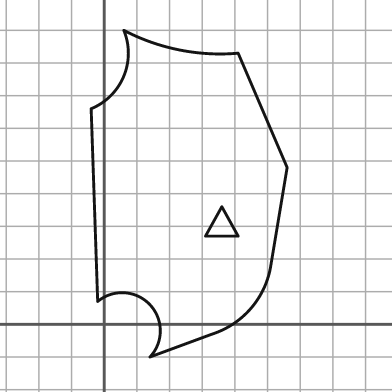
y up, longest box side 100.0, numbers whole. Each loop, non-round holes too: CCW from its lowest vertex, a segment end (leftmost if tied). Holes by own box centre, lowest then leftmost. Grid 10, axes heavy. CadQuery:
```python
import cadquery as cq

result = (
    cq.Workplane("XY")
    .moveTo(14.0, -10.0)
    .lineTo(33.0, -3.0)
    .threePointArc((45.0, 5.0), (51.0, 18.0))
    .lineTo(56.0, 48.0)
    .lineTo(41.0, 83.0)
    .threePointArc((23.0, 84.0), (6.0, 90.0))
    .threePointArc((6.0, 76.0), (-4.0, 66.0))
    .lineTo(-2.0, 7.0)
    .threePointArc((14.0, 6.0), (14.0, -10.0))
    .close()
    .moveTo(31.0, 27.0)
    .lineTo(41.0, 27.0)
    .lineTo(36.0, 36.0)
    .close()
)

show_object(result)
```